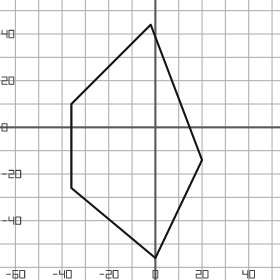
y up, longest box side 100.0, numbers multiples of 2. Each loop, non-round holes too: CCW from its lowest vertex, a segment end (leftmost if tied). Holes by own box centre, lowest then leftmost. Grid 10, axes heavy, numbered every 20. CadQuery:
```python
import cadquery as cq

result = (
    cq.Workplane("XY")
    .moveTo(0.0, -56.0)
    .lineTo(20.0, -14.0)
    .lineTo(-2.0, 44.0)
    .lineTo(-36.0, 10.0)
    .lineTo(-36.0, -26.0)
    .close()
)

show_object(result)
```